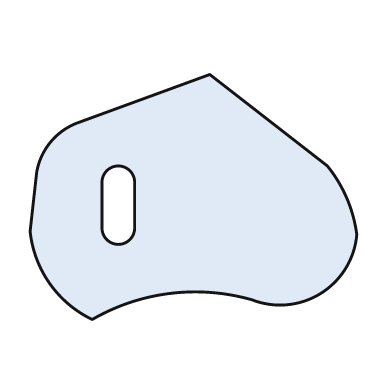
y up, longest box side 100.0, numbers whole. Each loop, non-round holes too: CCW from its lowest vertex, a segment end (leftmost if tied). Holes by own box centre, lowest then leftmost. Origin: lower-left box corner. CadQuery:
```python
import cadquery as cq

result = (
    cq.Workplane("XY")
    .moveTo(19.0, 0.0)
    .threePointArc((43.0, 8.0), (68.0, 6.0))
    .threePointArc((89.0, 8.0), (100.0, 26.0))
    .threePointArc((97.0, 37.0), (91.0, 47.0))
    .lineTo(55.0, 75.0)
    .lineTo(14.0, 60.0)
    .threePointArc((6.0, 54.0), (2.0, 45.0))
    .lineTo(0.0, 27.0)
    .threePointArc((6.0, 11.0), (19.0, 0.0))
    .close()
    .moveTo(22.0, 28.0)
    .threePointArc((27.0, 23.0), (32.0, 28.0))
    .lineTo(32.0, 42.0)
    .threePointArc((27.0, 47.0), (22.0, 42.0))
    .close()
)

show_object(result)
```